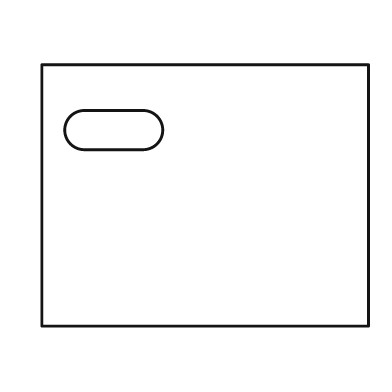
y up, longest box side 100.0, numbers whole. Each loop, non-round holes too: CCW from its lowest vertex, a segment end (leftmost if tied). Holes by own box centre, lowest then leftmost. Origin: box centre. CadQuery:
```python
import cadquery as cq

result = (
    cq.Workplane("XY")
    .moveTo(-50.0, -40.0)
    .lineTo(50.0, -40.0)
    .lineTo(50.0, 40.0)
    .lineTo(-50.0, 40.0)
    .close()
    .moveTo(-37.0, 14.0)
    .lineTo(-19.0, 14.0)
    .threePointArc((-13.0, 20.0), (-19.0, 26.0))
    .lineTo(-37.0, 26.0)
    .threePointArc((-43.0, 20.0), (-37.0, 14.0))
    .close()
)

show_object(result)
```